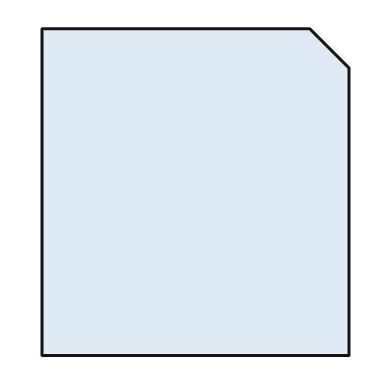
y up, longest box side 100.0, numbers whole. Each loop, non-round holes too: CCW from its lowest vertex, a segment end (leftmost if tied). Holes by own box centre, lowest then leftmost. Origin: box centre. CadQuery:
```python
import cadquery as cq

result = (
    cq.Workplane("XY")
    .moveTo(-47.0, -50.0)
    .lineTo(47.0, -50.0)
    .lineTo(47.0, 38.0)
    .lineTo(35.0, 50.0)
    .lineTo(-47.0, 50.0)
    .close()
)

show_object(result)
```